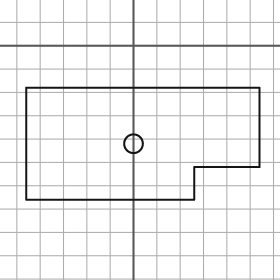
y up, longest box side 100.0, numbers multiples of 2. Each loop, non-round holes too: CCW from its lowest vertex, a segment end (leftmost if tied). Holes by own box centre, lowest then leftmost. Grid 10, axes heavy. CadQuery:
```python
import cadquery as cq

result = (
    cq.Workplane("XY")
    .moveTo(-46.0, -66.0)
    .lineTo(26.0, -66.0)
    .lineTo(26.0, -52.0)
    .lineTo(54.0, -52.0)
    .lineTo(54.0, -18.0)
    .lineTo(-46.0, -18.0)
    .close()
    .moveTo(0.0, -42.0)
    .circle(4.0)
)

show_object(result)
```